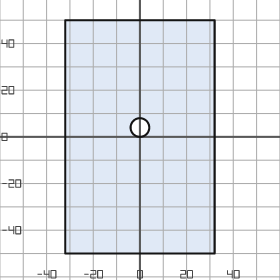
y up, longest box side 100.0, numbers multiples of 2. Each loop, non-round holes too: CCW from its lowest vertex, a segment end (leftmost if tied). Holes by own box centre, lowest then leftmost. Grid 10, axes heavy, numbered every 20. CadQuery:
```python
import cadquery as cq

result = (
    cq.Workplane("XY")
    .moveTo(-32.0, -50.0)
    .lineTo(32.0, -50.0)
    .lineTo(32.0, 50.0)
    .lineTo(-32.0, 50.0)
    .close()
    .moveTo(0.0, 4.0)
    .circle(4.0)
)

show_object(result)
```